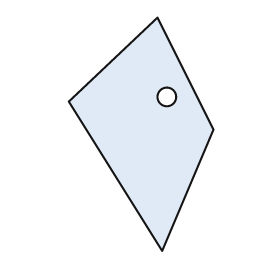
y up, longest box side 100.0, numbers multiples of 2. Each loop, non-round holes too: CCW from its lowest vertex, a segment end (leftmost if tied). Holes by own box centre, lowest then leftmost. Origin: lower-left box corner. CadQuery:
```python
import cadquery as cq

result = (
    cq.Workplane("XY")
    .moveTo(40.0, 0.0)
    .lineTo(62.0, 52.0)
    .lineTo(38.0, 100.0)
    .lineTo(0.0, 64.0)
    .close()
    .moveTo(42.0, 66.0)
    .circle(4.0)
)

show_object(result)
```